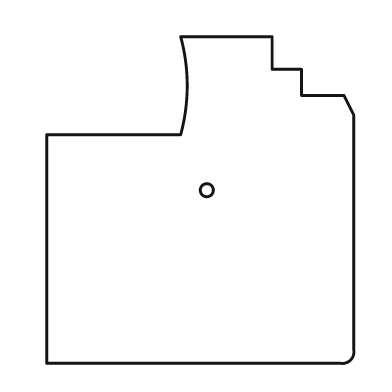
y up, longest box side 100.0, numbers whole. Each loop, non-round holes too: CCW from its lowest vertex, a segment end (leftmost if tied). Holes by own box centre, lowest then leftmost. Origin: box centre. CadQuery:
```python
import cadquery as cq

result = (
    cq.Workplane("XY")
    .moveTo(-47.0, -50.0)
    .lineTo(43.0, -50.0)
    .threePointArc((46.0, -49.0), (47.0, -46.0))
    .lineTo(47.0, 26.0)
    .lineTo(44.0, 32.0)
    .lineTo(31.0, 32.0)
    .lineTo(31.0, 40.0)
    .lineTo(22.0, 40.0)
    .lineTo(22.0, 50.0)
    .lineTo(-6.0, 50.0)
    .threePointArc((-4.0, 35.0), (-6.0, 20.0))
    .lineTo(-47.0, 20.0)
    .close()
    .moveTo(2.0, 3.0)
    .circle(2.0)
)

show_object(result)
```